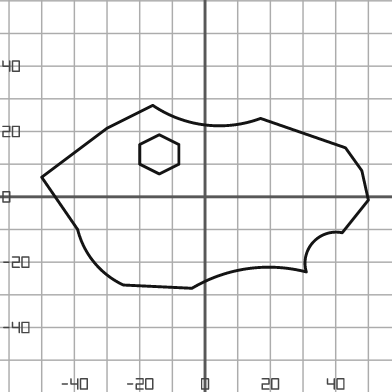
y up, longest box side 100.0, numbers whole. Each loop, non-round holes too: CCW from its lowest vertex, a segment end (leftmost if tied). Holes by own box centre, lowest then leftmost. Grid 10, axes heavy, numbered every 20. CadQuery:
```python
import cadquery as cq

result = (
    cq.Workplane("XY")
    .moveTo(-4.0, -28.0)
    .threePointArc((13.0, -22.0), (31.0, -23.0))
    .threePointArc((33.0, -14.0), (42.0, -11.0))
    .lineTo(50.0, -1.0)
    .lineTo(48.0, 8.0)
    .lineTo(43.0, 15.0)
    .lineTo(17.0, 24.0)
    .threePointArc((0.0, 22.0), (-16.0, 28.0))
    .lineTo(-30.0, 21.0)
    .lineTo(-50.0, 6.0)
    .lineTo(-39.0, -10.0)
    .threePointArc((-34.0, -20.0), (-25.0, -27.0))
    .close()
    .moveTo(-14.0, 7.0)
    .lineTo(-8.0, 10.0)
    .lineTo(-8.0, 16.0)
    .lineTo(-14.0, 19.0)
    .lineTo(-20.0, 16.0)
    .lineTo(-20.0, 10.0)
    .close()
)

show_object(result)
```